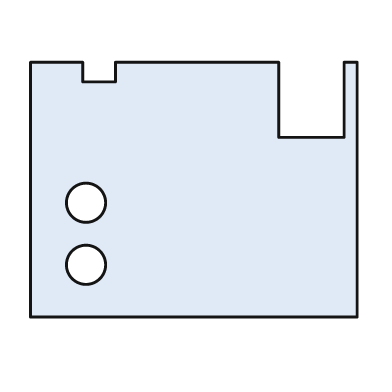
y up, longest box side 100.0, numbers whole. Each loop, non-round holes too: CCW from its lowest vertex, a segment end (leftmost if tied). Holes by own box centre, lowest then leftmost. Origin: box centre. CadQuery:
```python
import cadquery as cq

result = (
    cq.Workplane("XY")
    .moveTo(-50.0, -39.0)
    .lineTo(50.0, -39.0)
    .lineTo(50.0, 39.0)
    .lineTo(46.0, 39.0)
    .lineTo(46.0, 16.0)
    .lineTo(26.0, 16.0)
    .lineTo(26.0, 39.0)
    .lineTo(-24.0, 39.0)
    .lineTo(-24.0, 33.0)
    .lineTo(-34.0, 33.0)
    .lineTo(-34.0, 39.0)
    .lineTo(-50.0, 39.0)
    .close()
    .moveTo(-33.0, -23.0)
    .circle(6.0)
    .moveTo(-33.0, -4.0)
    .circle(6.0)
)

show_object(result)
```